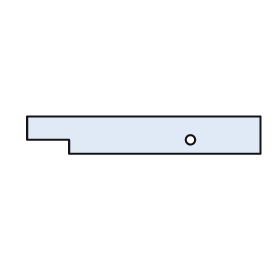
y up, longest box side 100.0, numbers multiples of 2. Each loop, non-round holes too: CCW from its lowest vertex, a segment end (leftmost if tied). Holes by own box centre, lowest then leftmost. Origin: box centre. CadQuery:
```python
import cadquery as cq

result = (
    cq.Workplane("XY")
    .moveTo(-32.0, -8.0)
    .lineTo(50.0, -8.0)
    .lineTo(50.0, 8.0)
    .lineTo(-50.0, 8.0)
    .lineTo(-50.0, -2.0)
    .lineTo(-32.0, -2.0)
    .close()
    .moveTo(20.0, -2.0)
    .circle(2.0)
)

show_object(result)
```